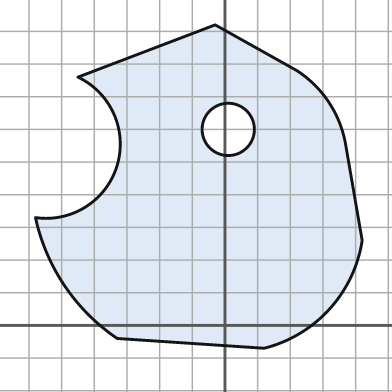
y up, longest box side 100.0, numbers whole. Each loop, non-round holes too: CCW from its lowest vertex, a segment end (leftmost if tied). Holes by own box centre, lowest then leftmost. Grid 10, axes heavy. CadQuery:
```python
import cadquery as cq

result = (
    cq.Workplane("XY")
    .moveTo(12.0, -7.0)
    .threePointArc((32.0, 5.0), (42.0, 26.0))
    .lineTo(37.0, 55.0)
    .threePointArc((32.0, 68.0), (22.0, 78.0))
    .lineTo(-3.0, 92.0)
    .lineTo(-45.0, 76.0)
    .threePointArc((-33.0, 49.0), (-58.0, 33.0))
    .threePointArc((-49.0, 12.0), (-33.0, -4.0))
    .close()
    .moveTo(1.0, 60.0)
    .circle(8.0)
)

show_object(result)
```